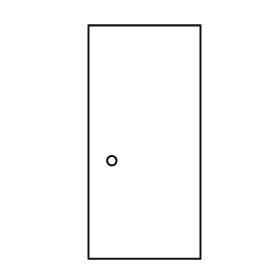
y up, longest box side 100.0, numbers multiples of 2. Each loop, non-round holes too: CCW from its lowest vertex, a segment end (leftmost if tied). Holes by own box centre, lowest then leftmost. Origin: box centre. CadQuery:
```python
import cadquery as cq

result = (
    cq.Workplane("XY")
    .moveTo(-24.0, -50.0)
    .lineTo(24.0, -50.0)
    .lineTo(24.0, 50.0)
    .lineTo(-24.0, 50.0)
    .close()
    .moveTo(-14.0, -8.0)
    .circle(2.0)
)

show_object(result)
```